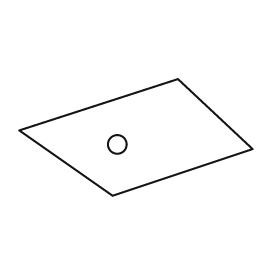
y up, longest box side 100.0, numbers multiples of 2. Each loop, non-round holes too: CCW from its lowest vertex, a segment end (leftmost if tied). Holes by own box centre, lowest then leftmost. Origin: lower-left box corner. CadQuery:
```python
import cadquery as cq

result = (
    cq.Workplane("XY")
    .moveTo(40.0, 0.0)
    .lineTo(100.0, 20.0)
    .lineTo(68.0, 50.0)
    .lineTo(0.0, 28.0)
    .close()
    .moveTo(42.0, 22.0)
    .circle(4.0)
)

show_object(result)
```